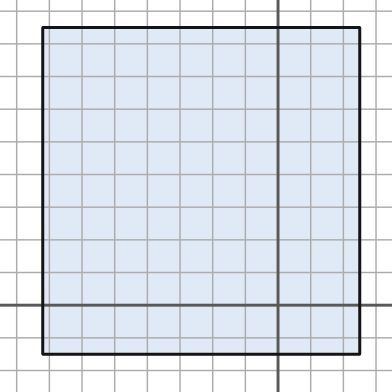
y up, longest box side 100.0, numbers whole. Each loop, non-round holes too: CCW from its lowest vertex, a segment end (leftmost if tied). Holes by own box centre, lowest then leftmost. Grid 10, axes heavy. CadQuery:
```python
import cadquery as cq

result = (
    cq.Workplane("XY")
    .moveTo(-72.0, -15.0)
    .lineTo(25.0, -15.0)
    .lineTo(25.0, 85.0)
    .lineTo(-72.0, 85.0)
    .close()
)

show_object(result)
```